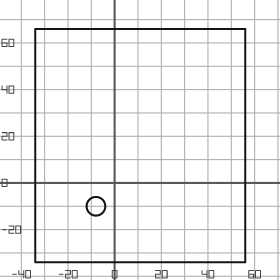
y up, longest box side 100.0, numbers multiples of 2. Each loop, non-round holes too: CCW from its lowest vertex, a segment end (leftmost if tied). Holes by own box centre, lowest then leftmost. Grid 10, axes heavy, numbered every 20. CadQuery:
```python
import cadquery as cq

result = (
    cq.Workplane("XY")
    .moveTo(-34.0, -34.0)
    .lineTo(56.0, -34.0)
    .lineTo(56.0, 66.0)
    .lineTo(-34.0, 66.0)
    .close()
    .moveTo(-8.0, -10.0)
    .circle(4.0)
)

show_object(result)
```